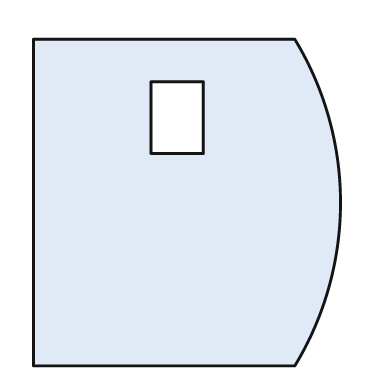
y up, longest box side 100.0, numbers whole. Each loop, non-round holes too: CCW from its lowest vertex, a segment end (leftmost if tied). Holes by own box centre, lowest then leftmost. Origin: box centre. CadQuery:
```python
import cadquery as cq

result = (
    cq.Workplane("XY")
    .moveTo(-47.0, -50.0)
    .lineTo(33.0, -50.0)
    .threePointArc((47.0, 0.0), (33.0, 50.0))
    .lineTo(-47.0, 50.0)
    .close()
    .moveTo(-11.0, 15.0)
    .lineTo(5.0, 15.0)
    .lineTo(5.0, 37.0)
    .lineTo(-11.0, 37.0)
    .close()
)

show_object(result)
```